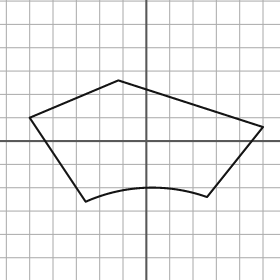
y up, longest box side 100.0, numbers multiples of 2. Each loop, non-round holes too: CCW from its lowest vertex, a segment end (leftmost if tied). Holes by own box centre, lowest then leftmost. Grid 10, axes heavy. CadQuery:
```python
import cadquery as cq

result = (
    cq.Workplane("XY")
    .moveTo(-26.0, -26.0)
    .threePointArc((0.0, -20.0), (26.0, -24.0))
    .lineTo(50.0, 6.0)
    .lineTo(-12.0, 26.0)
    .lineTo(-50.0, 10.0)
    .close()
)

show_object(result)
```